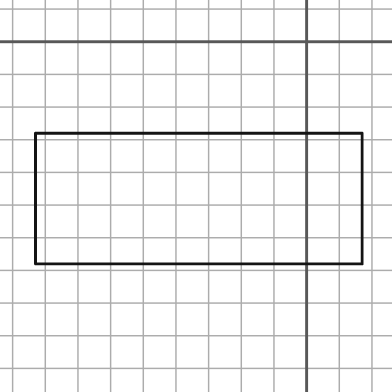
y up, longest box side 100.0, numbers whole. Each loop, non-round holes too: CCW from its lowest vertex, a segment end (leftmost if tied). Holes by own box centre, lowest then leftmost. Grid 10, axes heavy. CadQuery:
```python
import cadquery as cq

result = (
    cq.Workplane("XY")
    .moveTo(-83.0, -68.0)
    .lineTo(17.0, -68.0)
    .lineTo(17.0, -28.0)
    .lineTo(-83.0, -28.0)
    .close()
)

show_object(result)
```